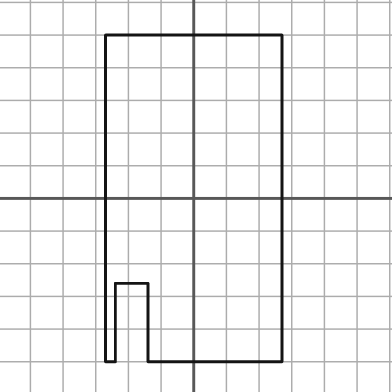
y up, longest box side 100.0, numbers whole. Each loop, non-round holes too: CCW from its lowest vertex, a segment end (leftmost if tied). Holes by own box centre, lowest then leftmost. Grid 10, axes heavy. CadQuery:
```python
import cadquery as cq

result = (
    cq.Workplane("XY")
    .moveTo(-27.0, -50.0)
    .lineTo(-24.0, -50.0)
    .lineTo(-24.0, -26.0)
    .lineTo(-14.0, -26.0)
    .lineTo(-14.0, -50.0)
    .lineTo(27.0, -50.0)
    .lineTo(27.0, 50.0)
    .lineTo(-27.0, 50.0)
    .close()
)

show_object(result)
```